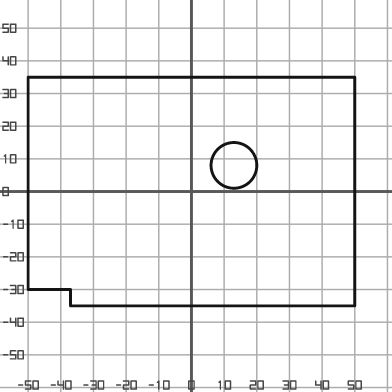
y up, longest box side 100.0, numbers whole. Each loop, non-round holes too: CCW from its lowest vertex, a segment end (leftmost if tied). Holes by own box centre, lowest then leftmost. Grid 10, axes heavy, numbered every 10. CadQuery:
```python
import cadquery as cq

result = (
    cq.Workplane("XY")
    .moveTo(-37.0, -35.0)
    .lineTo(50.0, -35.0)
    .lineTo(50.0, 35.0)
    .lineTo(-50.0, 35.0)
    .lineTo(-50.0, -30.0)
    .lineTo(-37.0, -30.0)
    .close()
    .moveTo(13.0, 8.0)
    .circle(7.0)
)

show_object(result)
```